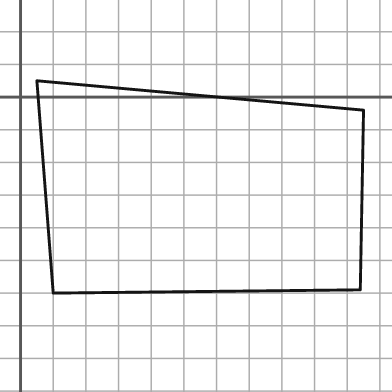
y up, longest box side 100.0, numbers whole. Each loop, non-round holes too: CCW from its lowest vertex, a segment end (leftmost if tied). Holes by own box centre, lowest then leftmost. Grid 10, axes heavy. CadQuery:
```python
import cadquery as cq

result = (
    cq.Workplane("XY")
    .moveTo(10.0, -60.0)
    .lineTo(104.0, -59.0)
    .lineTo(105.0, -4.0)
    .lineTo(5.0, 5.0)
    .close()
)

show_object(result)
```